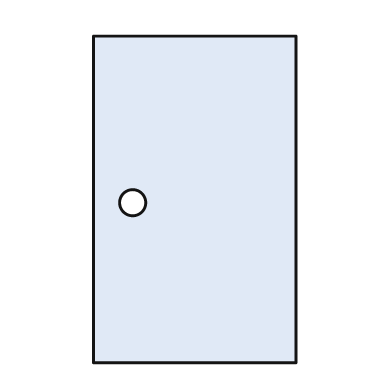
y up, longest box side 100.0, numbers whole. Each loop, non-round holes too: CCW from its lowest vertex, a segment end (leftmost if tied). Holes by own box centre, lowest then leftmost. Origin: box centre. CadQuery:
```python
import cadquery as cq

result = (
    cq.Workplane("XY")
    .moveTo(-31.0, -50.0)
    .lineTo(31.0, -50.0)
    .lineTo(31.0, 50.0)
    .lineTo(-31.0, 50.0)
    .close()
    .moveTo(-19.0, -1.0)
    .circle(4.0)
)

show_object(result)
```